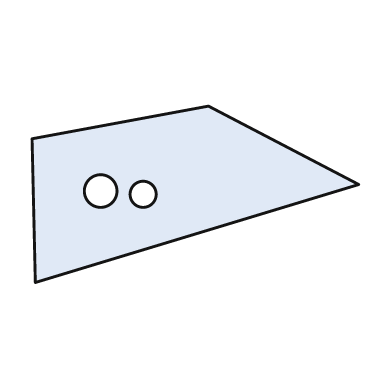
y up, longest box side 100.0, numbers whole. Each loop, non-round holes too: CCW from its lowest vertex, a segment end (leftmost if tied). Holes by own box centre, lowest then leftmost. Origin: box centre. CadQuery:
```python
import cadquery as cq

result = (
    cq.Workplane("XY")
    .moveTo(-49.0, -27.0)
    .lineTo(50.0, 3.0)
    .lineTo(4.0, 27.0)
    .lineTo(-50.0, 17.0)
    .close()
    .moveTo(-16.0, 0.0)
    .circle(4.0)
    .moveTo(-29.0, 1.0)
    .circle(5.0)
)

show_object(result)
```